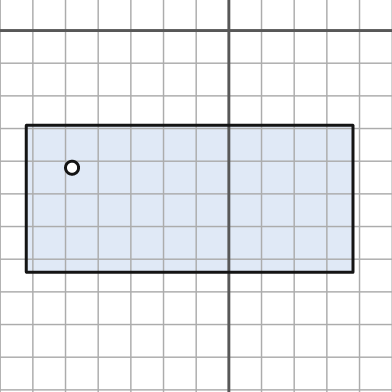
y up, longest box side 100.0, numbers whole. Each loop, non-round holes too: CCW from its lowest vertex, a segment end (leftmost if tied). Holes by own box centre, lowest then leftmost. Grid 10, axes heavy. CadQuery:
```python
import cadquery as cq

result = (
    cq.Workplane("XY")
    .moveTo(-62.0, -74.0)
    .lineTo(38.0, -74.0)
    .lineTo(38.0, -29.0)
    .lineTo(-62.0, -29.0)
    .close()
    .moveTo(-48.0, -42.0)
    .circle(2.0)
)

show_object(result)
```